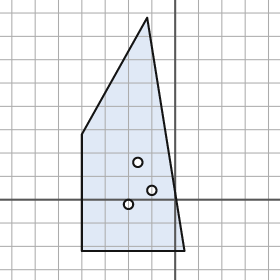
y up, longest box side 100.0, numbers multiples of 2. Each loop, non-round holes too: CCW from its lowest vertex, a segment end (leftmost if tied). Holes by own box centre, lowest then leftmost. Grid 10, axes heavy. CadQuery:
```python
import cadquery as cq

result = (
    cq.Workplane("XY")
    .moveTo(-40.0, -22.0)
    .lineTo(4.0, -22.0)
    .lineTo(-12.0, 78.0)
    .lineTo(-40.0, 28.0)
    .close()
    .moveTo(-20.0, -2.0)
    .circle(2.0)
    .moveTo(-10.0, 4.0)
    .circle(2.0)
    .moveTo(-16.0, 16.0)
    .circle(2.0)
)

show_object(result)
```